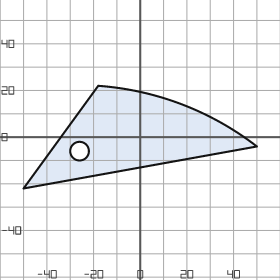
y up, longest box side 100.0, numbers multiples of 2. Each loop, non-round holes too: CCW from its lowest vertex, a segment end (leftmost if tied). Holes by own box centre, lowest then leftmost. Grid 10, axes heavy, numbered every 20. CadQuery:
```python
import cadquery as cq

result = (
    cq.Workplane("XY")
    .moveTo(-50.0, -22.0)
    .lineTo(50.0, -4.0)
    .threePointArc((18.0, 14.0), (-18.0, 22.0))
    .close()
    .moveTo(-26.0, -6.0)
    .circle(4.0)
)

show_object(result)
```